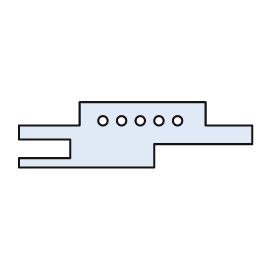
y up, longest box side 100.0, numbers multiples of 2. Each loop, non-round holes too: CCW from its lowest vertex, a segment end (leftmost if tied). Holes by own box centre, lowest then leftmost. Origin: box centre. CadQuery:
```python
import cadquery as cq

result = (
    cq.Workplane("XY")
    .moveTo(-50.0, -14.0)
    .lineTo(8.0, -14.0)
    .lineTo(8.0, -4.0)
    .lineTo(50.0, -4.0)
    .lineTo(50.0, 4.0)
    .lineTo(30.0, 4.0)
    .lineTo(30.0, 14.0)
    .lineTo(-24.0, 14.0)
    .lineTo(-24.0, 4.0)
    .lineTo(-50.0, 4.0)
    .lineTo(-50.0, -2.0)
    .lineTo(-28.0, -2.0)
    .lineTo(-28.0, -10.0)
    .lineTo(-50.0, -10.0)
    .close()
    .moveTo(-14.0, 6.0)
    .circle(2.0)
    .moveTo(-6.0, 6.0)
    .circle(2.0)
    .moveTo(2.0, 6.0)
    .circle(2.0)
    .moveTo(10.0, 6.0)
    .circle(2.0)
    .moveTo(18.0, 6.0)
    .circle(2.0)
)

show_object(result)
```